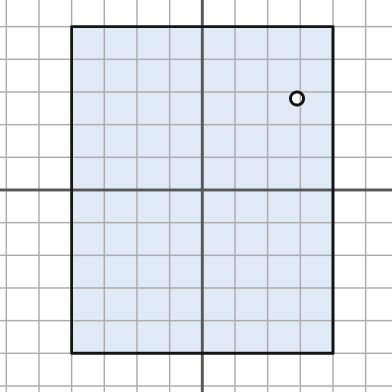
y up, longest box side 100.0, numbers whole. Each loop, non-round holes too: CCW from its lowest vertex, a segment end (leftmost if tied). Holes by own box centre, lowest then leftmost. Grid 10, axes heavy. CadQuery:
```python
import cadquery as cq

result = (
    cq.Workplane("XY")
    .moveTo(-40.0, -50.0)
    .lineTo(40.0, -50.0)
    .lineTo(40.0, 50.0)
    .lineTo(-40.0, 50.0)
    .close()
    .moveTo(29.0, 28.0)
    .circle(2.0)
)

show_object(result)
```